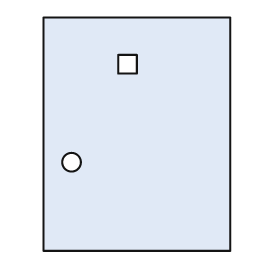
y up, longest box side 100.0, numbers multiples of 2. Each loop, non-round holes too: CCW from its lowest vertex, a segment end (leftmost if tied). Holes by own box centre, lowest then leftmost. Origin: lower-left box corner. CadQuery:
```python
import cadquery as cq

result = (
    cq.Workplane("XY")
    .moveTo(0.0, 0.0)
    .lineTo(80.0, 0.0)
    .lineTo(80.0, 100.0)
    .lineTo(0.0, 100.0)
    .close()
    .moveTo(12.0, 38.0)
    .circle(4.0)
    .moveTo(32.0, 76.0)
    .lineTo(40.0, 76.0)
    .lineTo(40.0, 84.0)
    .lineTo(32.0, 84.0)
    .close()
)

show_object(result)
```